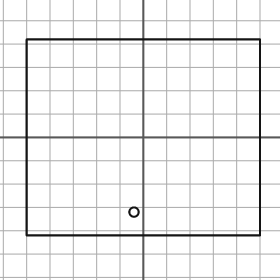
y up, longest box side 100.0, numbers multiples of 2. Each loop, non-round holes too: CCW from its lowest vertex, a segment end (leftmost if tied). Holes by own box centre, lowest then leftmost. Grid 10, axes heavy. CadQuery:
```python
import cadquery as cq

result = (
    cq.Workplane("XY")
    .moveTo(-50.0, -42.0)
    .lineTo(50.0, -42.0)
    .lineTo(50.0, 42.0)
    .lineTo(-50.0, 42.0)
    .close()
    .moveTo(-4.0, -32.0)
    .circle(2.0)
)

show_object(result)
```